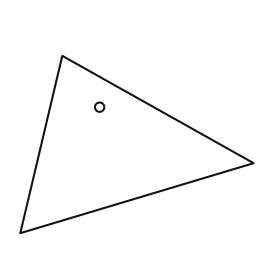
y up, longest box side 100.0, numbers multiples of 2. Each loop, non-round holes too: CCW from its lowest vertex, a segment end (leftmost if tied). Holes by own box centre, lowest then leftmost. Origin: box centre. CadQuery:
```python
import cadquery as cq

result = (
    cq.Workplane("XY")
    .moveTo(-50.0, -38.0)
    .lineTo(50.0, -8.0)
    .lineTo(-32.0, 38.0)
    .close()
    .moveTo(-16.0, 16.0)
    .circle(2.0)
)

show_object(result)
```